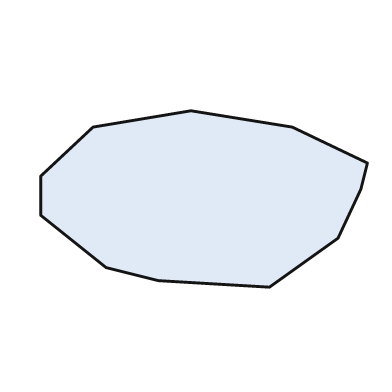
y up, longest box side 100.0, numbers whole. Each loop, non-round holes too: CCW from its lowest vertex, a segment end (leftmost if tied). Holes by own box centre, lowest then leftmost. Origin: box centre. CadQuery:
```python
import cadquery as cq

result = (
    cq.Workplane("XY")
    .moveTo(20.0, -27.0)
    .lineTo(41.0, -12.0)
    .lineTo(48.0, 3.0)
    .lineTo(50.0, 11.0)
    .lineTo(27.0, 22.0)
    .lineTo(-4.0, 27.0)
    .lineTo(-34.0, 22.0)
    .lineTo(-50.0, 7.0)
    .lineTo(-50.0, -5.0)
    .lineTo(-30.0, -21.0)
    .lineTo(-14.0, -25.0)
    .close()
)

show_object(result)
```